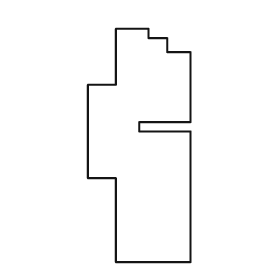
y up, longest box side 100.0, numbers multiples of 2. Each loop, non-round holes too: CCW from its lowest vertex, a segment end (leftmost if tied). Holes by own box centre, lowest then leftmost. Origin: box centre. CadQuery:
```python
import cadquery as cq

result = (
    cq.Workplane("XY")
    .moveTo(-10.0, -50.0)
    .lineTo(22.0, -50.0)
    .lineTo(22.0, 6.0)
    .lineTo(0.0, 6.0)
    .lineTo(0.0, 10.0)
    .lineTo(22.0, 10.0)
    .lineTo(22.0, 40.0)
    .lineTo(12.0, 40.0)
    .lineTo(12.0, 46.0)
    .lineTo(4.0, 46.0)
    .lineTo(4.0, 50.0)
    .lineTo(-10.0, 50.0)
    .lineTo(-10.0, 26.0)
    .lineTo(-22.0, 26.0)
    .lineTo(-22.0, -14.0)
    .lineTo(-10.0, -14.0)
    .close()
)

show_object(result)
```